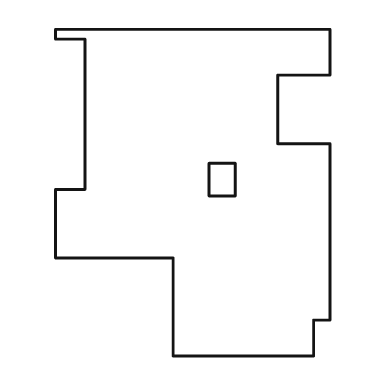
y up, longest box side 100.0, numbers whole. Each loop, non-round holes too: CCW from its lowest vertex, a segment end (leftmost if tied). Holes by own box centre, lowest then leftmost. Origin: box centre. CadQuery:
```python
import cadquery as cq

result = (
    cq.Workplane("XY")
    .moveTo(-6.0, -50.0)
    .lineTo(37.0, -50.0)
    .lineTo(37.0, -39.0)
    .lineTo(42.0, -39.0)
    .lineTo(42.0, 15.0)
    .lineTo(26.0, 15.0)
    .lineTo(26.0, 36.0)
    .lineTo(42.0, 36.0)
    .lineTo(42.0, 50.0)
    .lineTo(-42.0, 50.0)
    .lineTo(-42.0, 47.0)
    .lineTo(-33.0, 47.0)
    .lineTo(-33.0, 1.0)
    .lineTo(-42.0, 1.0)
    .lineTo(-42.0, -20.0)
    .lineTo(-6.0, -20.0)
    .close()
    .moveTo(5.0, -1.0)
    .lineTo(13.0, -1.0)
    .lineTo(13.0, 9.0)
    .lineTo(5.0, 9.0)
    .close()
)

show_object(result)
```